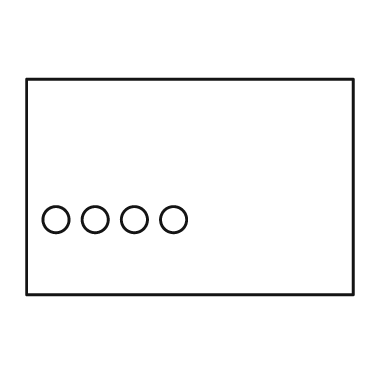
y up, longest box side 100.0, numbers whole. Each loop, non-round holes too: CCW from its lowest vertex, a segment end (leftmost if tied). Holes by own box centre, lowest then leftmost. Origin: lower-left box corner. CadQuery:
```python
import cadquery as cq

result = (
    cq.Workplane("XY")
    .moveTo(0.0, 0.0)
    .lineTo(100.0, 0.0)
    .lineTo(100.0, 66.0)
    .lineTo(0.0, 66.0)
    .close()
    .moveTo(9.0, 23.0)
    .circle(4.0)
    .moveTo(21.0, 23.0)
    .circle(4.0)
    .moveTo(33.0, 23.0)
    .circle(4.0)
    .moveTo(45.0, 23.0)
    .circle(4.0)
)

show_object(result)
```